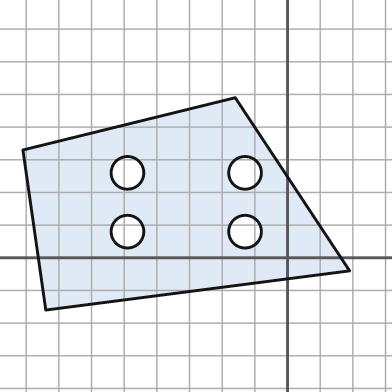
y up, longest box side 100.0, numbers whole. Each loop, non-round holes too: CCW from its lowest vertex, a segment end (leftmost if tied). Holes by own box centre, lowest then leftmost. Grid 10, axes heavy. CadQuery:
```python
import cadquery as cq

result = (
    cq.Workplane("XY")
    .moveTo(-74.0, -16.0)
    .lineTo(19.0, -4.0)
    .lineTo(-16.0, 49.0)
    .lineTo(-81.0, 33.0)
    .close()
    .moveTo(-49.0, 8.0)
    .circle(5.0)
    .moveTo(-13.0, 8.0)
    .circle(5.0)
    .moveTo(-49.0, 26.0)
    .circle(5.0)
    .moveTo(-13.0, 26.0)
    .circle(5.0)
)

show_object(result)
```